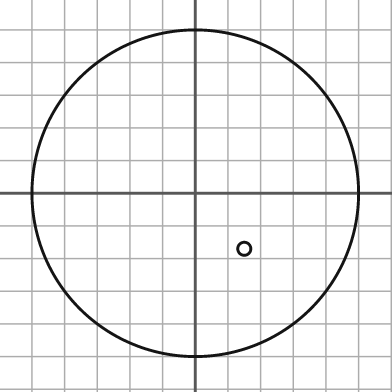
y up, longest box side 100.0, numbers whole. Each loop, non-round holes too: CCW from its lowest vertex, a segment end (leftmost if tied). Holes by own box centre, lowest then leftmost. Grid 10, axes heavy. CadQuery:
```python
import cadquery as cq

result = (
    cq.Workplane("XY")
    .moveTo(0.0, 0.0)
    .circle(50.0)
    .moveTo(15.0, -17.0)
    .circle(2.0)
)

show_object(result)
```